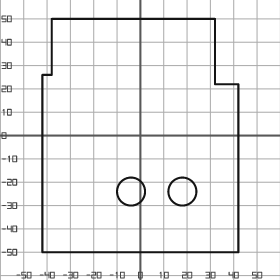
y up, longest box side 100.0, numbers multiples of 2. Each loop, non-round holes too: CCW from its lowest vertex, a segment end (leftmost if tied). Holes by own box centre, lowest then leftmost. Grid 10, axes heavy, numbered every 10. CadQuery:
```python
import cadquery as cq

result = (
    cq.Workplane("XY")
    .moveTo(-42.0, -50.0)
    .lineTo(42.0, -50.0)
    .lineTo(42.0, 22.0)
    .lineTo(32.0, 22.0)
    .lineTo(32.0, 50.0)
    .lineTo(-38.0, 50.0)
    .lineTo(-38.0, 26.0)
    .lineTo(-42.0, 26.0)
    .close()
    .moveTo(-4.0, -24.0)
    .circle(6.0)
    .moveTo(18.0, -24.0)
    .circle(6.0)
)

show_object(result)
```